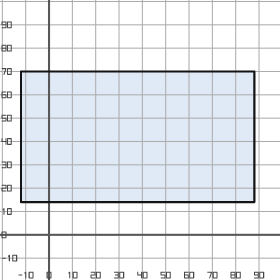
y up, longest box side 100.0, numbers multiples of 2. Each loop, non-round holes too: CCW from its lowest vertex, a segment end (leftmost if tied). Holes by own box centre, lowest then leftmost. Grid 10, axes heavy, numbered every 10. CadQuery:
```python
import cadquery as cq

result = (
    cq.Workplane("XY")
    .moveTo(-12.0, 14.0)
    .lineTo(88.0, 14.0)
    .lineTo(88.0, 70.0)
    .lineTo(-12.0, 70.0)
    .close()
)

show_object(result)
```